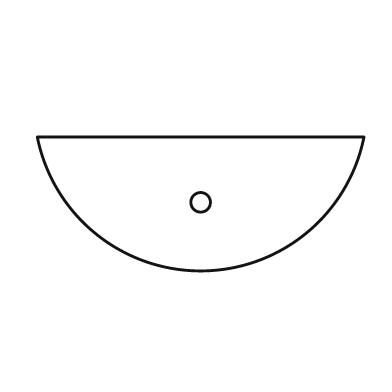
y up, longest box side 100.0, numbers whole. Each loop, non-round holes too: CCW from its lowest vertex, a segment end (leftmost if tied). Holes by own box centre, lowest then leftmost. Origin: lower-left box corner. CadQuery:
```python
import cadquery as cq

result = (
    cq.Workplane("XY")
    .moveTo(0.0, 41.0)
    .threePointArc((50.0, 0.0), (100.0, 41.0))
    .close()
    .moveTo(50.0, 21.0)
    .circle(3.0)
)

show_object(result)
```